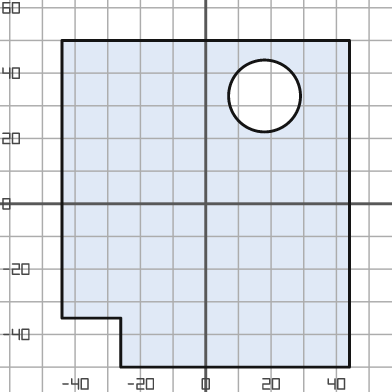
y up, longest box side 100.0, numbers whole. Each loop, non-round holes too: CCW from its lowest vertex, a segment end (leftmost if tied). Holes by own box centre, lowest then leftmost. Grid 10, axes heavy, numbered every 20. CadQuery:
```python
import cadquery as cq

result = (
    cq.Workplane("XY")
    .moveTo(-26.0, -50.0)
    .lineTo(44.0, -50.0)
    .lineTo(44.0, 50.0)
    .lineTo(-44.0, 50.0)
    .lineTo(-44.0, -35.0)
    .lineTo(-26.0, -35.0)
    .close()
    .moveTo(18.0, 33.0)
    .circle(11.0)
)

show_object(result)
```